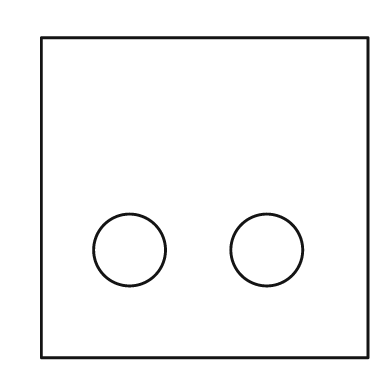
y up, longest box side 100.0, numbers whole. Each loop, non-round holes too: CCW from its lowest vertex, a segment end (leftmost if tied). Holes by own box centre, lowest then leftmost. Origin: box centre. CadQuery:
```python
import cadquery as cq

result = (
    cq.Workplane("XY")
    .moveTo(-50.0, -49.0)
    .lineTo(50.0, -49.0)
    .lineTo(50.0, 49.0)
    .lineTo(-50.0, 49.0)
    .close()
    .moveTo(-23.0, -16.0)
    .circle(11.0)
    .moveTo(19.0, -16.0)
    .circle(11.0)
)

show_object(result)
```